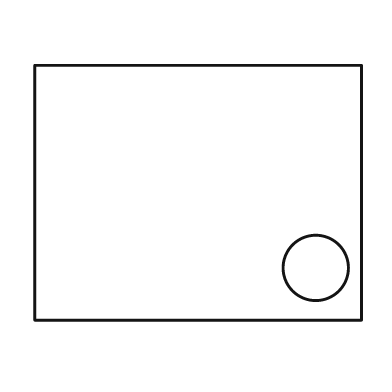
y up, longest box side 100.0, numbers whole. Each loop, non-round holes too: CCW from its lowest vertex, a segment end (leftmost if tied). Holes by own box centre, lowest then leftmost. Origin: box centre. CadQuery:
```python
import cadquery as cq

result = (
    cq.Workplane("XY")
    .moveTo(-50.0, -39.0)
    .lineTo(50.0, -39.0)
    .lineTo(50.0, 39.0)
    .lineTo(-50.0, 39.0)
    .close()
    .moveTo(36.0, -23.0)
    .circle(10.0)
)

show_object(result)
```